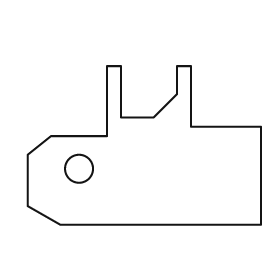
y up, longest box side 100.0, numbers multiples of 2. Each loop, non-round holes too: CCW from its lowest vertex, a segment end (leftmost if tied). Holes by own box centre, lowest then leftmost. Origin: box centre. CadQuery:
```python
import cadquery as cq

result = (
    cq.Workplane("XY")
    .moveTo(-36.0, -34.0)
    .lineTo(50.0, -34.0)
    .lineTo(50.0, 8.0)
    .lineTo(20.0, 8.0)
    .lineTo(20.0, 34.0)
    .lineTo(14.0, 34.0)
    .lineTo(14.0, 22.0)
    .lineTo(4.0, 12.0)
    .lineTo(-10.0, 12.0)
    .lineTo(-10.0, 34.0)
    .lineTo(-16.0, 34.0)
    .lineTo(-16.0, 4.0)
    .lineTo(-40.0, 4.0)
    .lineTo(-50.0, -4.0)
    .lineTo(-50.0, -26.0)
    .close()
    .moveTo(-28.0, -10.0)
    .circle(6.0)
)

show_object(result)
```